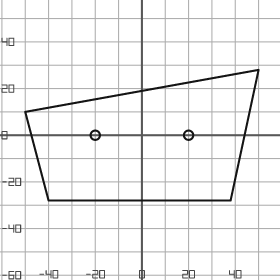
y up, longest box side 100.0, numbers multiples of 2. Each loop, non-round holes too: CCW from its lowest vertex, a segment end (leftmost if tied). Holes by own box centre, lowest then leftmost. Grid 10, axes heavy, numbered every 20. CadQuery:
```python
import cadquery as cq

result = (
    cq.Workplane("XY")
    .moveTo(-40.0, -28.0)
    .lineTo(38.0, -28.0)
    .lineTo(50.0, 28.0)
    .lineTo(-50.0, 10.0)
    .close()
    .moveTo(-20.0, 0.0)
    .circle(2.0)
    .moveTo(20.0, 0.0)
    .circle(2.0)
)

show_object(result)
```